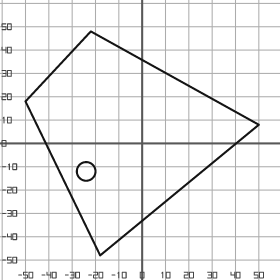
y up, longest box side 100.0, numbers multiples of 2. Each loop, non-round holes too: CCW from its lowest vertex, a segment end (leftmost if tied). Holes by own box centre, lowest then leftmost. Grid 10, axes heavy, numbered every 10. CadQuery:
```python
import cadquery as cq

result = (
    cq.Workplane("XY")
    .moveTo(-18.0, -48.0)
    .lineTo(50.0, 8.0)
    .lineTo(-22.0, 48.0)
    .lineTo(-50.0, 18.0)
    .close()
    .moveTo(-24.0, -12.0)
    .circle(4.0)
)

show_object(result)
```